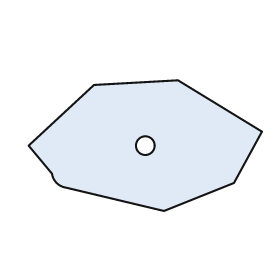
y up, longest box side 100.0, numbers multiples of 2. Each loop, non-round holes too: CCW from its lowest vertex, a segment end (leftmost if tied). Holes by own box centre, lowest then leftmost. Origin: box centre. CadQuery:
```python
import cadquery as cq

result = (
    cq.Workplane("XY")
    .moveTo(8.0, -28.0)
    .lineTo(38.0, -16.0)
    .lineTo(50.0, 6.0)
    .lineTo(14.0, 28.0)
    .lineTo(-22.0, 26.0)
    .lineTo(-50.0, 0.0)
    .lineTo(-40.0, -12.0)
    .threePointArc((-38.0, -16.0), (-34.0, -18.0))
    .close()
    .moveTo(0.0, 0.0)
    .circle(4.0)
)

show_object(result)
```